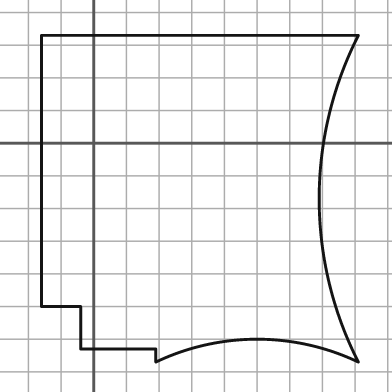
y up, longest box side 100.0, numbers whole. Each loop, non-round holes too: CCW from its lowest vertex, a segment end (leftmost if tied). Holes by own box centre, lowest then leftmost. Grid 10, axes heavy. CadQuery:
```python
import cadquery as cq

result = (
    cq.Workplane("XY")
    .moveTo(19.0, -67.0)
    .threePointArc((50.0, -60.0), (81.0, -67.0))
    .threePointArc((69.0, -17.0), (81.0, 33.0))
    .lineTo(-16.0, 33.0)
    .lineTo(-16.0, -50.0)
    .lineTo(-4.0, -50.0)
    .lineTo(-4.0, -63.0)
    .lineTo(19.0, -63.0)
    .close()
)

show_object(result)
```